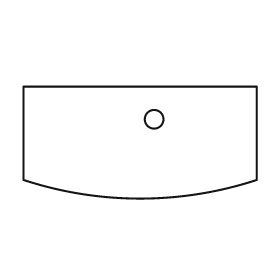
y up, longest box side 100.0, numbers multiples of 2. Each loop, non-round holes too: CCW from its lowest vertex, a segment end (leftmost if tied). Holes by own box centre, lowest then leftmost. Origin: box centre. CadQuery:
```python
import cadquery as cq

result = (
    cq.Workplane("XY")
    .moveTo(-50.0, -16.0)
    .threePointArc((0.0, -24.0), (50.0, -16.0))
    .lineTo(50.0, 24.0)
    .lineTo(-50.0, 24.0)
    .close()
    .moveTo(6.0, 10.0)
    .circle(4.0)
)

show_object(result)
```